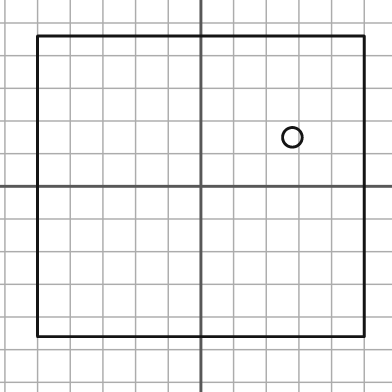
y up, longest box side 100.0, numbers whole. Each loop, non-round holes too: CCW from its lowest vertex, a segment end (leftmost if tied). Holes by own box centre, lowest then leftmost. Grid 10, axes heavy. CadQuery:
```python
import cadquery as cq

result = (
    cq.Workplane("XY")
    .moveTo(-50.0, -46.0)
    .lineTo(50.0, -46.0)
    .lineTo(50.0, 46.0)
    .lineTo(-50.0, 46.0)
    .close()
    .moveTo(28.0, 15.0)
    .circle(3.0)
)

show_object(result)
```